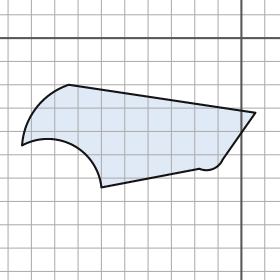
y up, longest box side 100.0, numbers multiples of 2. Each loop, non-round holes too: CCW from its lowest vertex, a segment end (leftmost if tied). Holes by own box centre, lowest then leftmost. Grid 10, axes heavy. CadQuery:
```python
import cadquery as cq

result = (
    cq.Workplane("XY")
    .moveTo(-60.0, -64.0)
    .lineTo(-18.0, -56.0)
    .threePointArc((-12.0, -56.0), (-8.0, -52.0))
    .lineTo(6.0, -32.0)
    .lineTo(-74.0, -20.0)
    .threePointArc((-88.0, -30.0), (-94.0, -46.0))
    .threePointArc((-72.0, -46.0), (-60.0, -64.0))
    .close()
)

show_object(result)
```